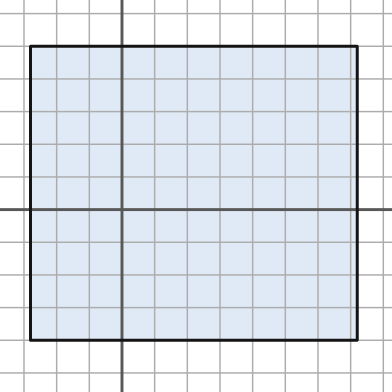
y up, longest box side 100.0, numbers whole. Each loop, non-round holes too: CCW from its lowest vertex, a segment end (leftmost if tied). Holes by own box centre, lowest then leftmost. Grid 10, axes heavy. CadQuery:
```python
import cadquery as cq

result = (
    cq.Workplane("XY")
    .moveTo(-28.0, -40.0)
    .lineTo(72.0, -40.0)
    .lineTo(72.0, 50.0)
    .lineTo(-28.0, 50.0)
    .close()
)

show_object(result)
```